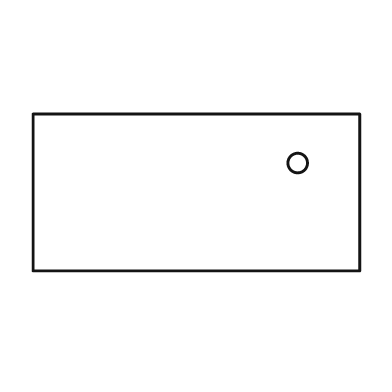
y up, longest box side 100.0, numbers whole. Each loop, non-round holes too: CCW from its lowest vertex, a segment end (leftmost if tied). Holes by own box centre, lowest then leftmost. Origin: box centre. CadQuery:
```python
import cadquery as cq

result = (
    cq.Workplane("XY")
    .moveTo(-50.0, -24.0)
    .lineTo(50.0, -24.0)
    .lineTo(50.0, 24.0)
    .lineTo(-50.0, 24.0)
    .close()
    .moveTo(31.0, 9.0)
    .circle(3.0)
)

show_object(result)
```